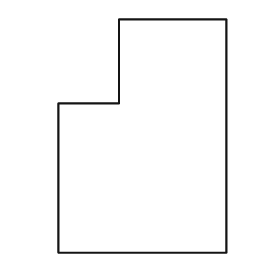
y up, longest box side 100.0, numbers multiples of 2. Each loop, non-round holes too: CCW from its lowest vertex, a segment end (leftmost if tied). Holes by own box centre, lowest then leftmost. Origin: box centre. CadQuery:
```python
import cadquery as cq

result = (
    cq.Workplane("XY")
    .moveTo(-36.0, -50.0)
    .lineTo(36.0, -50.0)
    .lineTo(36.0, 50.0)
    .lineTo(-10.0, 50.0)
    .lineTo(-10.0, 14.0)
    .lineTo(-36.0, 14.0)
    .close()
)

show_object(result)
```